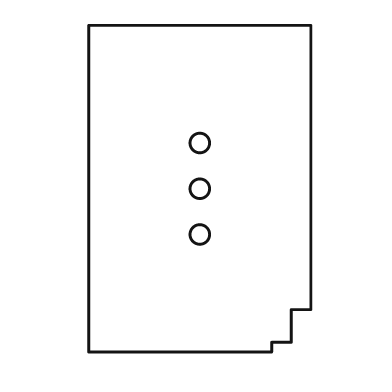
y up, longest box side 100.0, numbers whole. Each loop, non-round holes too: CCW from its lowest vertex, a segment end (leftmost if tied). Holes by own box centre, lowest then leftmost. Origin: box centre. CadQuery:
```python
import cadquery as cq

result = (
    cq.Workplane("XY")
    .moveTo(-34.0, -50.0)
    .lineTo(22.0, -50.0)
    .lineTo(22.0, -47.0)
    .lineTo(28.0, -47.0)
    .lineTo(28.0, -37.0)
    .lineTo(34.0, -37.0)
    .lineTo(34.0, 50.0)
    .lineTo(-34.0, 50.0)
    .close()
    .moveTo(0.0, -14.0)
    .circle(3.0)
    .moveTo(0.0, 0.0)
    .circle(3.0)
    .moveTo(0.0, 14.0)
    .circle(3.0)
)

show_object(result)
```